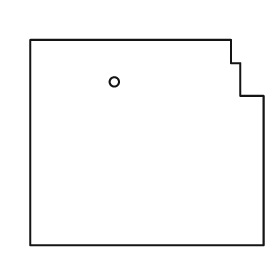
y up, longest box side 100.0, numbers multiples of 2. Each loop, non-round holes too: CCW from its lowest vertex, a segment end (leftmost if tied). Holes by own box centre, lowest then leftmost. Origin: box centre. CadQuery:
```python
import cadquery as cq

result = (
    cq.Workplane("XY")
    .moveTo(-50.0, -44.0)
    .lineTo(50.0, -44.0)
    .lineTo(50.0, 20.0)
    .lineTo(40.0, 20.0)
    .lineTo(40.0, 34.0)
    .lineTo(36.0, 34.0)
    .lineTo(36.0, 44.0)
    .lineTo(-50.0, 44.0)
    .close()
    .moveTo(-14.0, 26.0)
    .circle(2.0)
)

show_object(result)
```